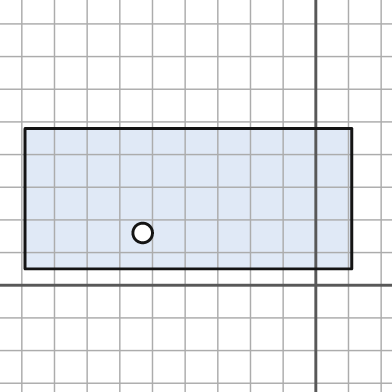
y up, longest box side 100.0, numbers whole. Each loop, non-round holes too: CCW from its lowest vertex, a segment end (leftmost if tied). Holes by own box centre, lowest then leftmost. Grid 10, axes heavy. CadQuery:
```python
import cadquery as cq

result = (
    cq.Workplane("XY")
    .moveTo(-89.0, 5.0)
    .lineTo(11.0, 5.0)
    .lineTo(11.0, 48.0)
    .lineTo(-89.0, 48.0)
    .close()
    .moveTo(-53.0, 16.0)
    .circle(3.0)
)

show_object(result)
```